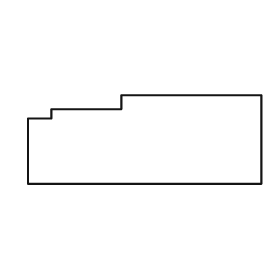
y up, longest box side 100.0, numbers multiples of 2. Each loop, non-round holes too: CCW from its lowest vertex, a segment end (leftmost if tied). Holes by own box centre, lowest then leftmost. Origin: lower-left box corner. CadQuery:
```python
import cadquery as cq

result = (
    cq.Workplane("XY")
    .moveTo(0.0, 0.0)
    .lineTo(100.0, 0.0)
    .lineTo(100.0, 38.0)
    .lineTo(40.0, 38.0)
    .lineTo(40.0, 32.0)
    .lineTo(10.0, 32.0)
    .lineTo(10.0, 28.0)
    .lineTo(0.0, 28.0)
    .close()
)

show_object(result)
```